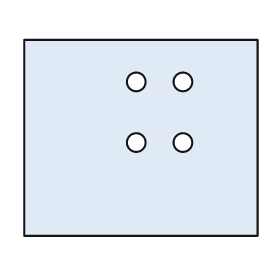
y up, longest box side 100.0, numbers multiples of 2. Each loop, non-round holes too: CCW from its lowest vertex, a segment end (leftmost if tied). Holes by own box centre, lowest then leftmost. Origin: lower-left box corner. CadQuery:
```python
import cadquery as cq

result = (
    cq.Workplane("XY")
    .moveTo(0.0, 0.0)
    .lineTo(100.0, 0.0)
    .lineTo(100.0, 84.0)
    .lineTo(0.0, 84.0)
    .close()
    .moveTo(48.0, 40.0)
    .circle(4.0)
    .moveTo(68.0, 40.0)
    .circle(4.0)
    .moveTo(48.0, 66.0)
    .circle(4.0)
    .moveTo(68.0, 66.0)
    .circle(4.0)
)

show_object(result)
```